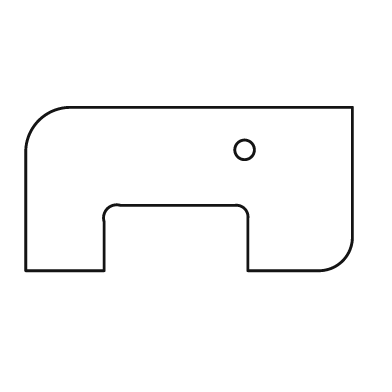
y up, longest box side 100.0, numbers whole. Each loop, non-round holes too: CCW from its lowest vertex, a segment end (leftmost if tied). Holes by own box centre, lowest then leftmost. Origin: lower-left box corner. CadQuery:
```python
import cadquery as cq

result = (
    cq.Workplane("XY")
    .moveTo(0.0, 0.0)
    .lineTo(24.0, 0.0)
    .lineTo(24.0, 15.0)
    .threePointArc((25.0, 19.0), (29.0, 20.0))
    .lineTo(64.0, 20.0)
    .threePointArc((67.0, 19.0), (68.0, 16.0))
    .lineTo(68.0, 0.0)
    .lineTo(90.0, 0.0)
    .threePointArc((97.0, 3.0), (100.0, 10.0))
    .lineTo(100.0, 50.0)
    .lineTo(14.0, 50.0)
    .threePointArc((4.0, 46.0), (0.0, 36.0))
    .close()
    .moveTo(67.0, 37.0)
    .circle(3.0)
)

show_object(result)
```